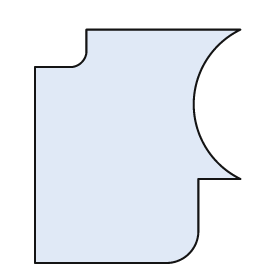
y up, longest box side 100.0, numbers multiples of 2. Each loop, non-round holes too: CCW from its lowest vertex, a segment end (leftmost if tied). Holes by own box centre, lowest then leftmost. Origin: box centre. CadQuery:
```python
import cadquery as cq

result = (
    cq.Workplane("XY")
    .moveTo(-44.0, -50.0)
    .lineTo(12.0, -50.0)
    .threePointArc((22.0, -46.0), (26.0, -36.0))
    .lineTo(26.0, -14.0)
    .lineTo(44.0, -14.0)
    .threePointArc((24.0, 18.0), (44.0, 50.0))
    .lineTo(-22.0, 50.0)
    .lineTo(-22.0, 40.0)
    .threePointArc((-24.0, 36.0), (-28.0, 34.0))
    .lineTo(-44.0, 34.0)
    .close()
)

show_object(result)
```